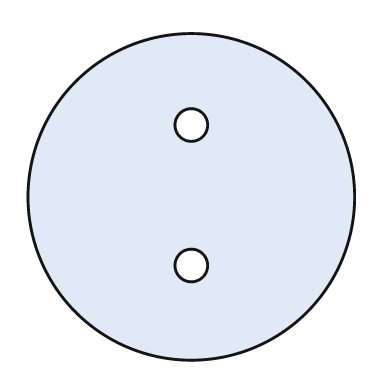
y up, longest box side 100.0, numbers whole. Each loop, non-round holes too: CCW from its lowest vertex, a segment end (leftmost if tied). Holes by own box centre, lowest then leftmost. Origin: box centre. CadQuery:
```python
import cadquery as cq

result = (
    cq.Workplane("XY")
    .moveTo(0.0, 0.0)
    .circle(50.0)
    .moveTo(0.0, -21.0)
    .circle(5.0)
    .moveTo(0.0, 22.0)
    .circle(5.0)
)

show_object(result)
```